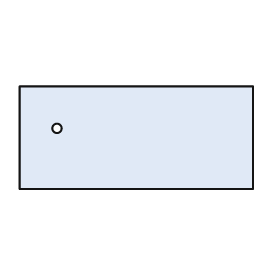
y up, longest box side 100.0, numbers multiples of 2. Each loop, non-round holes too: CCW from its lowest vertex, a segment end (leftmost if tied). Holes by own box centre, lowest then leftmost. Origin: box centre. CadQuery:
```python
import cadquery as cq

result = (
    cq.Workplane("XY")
    .moveTo(-50.0, -22.0)
    .lineTo(50.0, -22.0)
    .lineTo(50.0, 22.0)
    .lineTo(-50.0, 22.0)
    .close()
    .moveTo(-34.0, 4.0)
    .circle(2.0)
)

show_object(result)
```